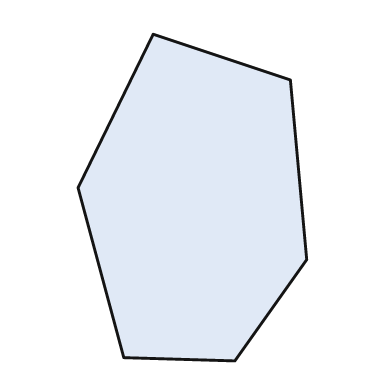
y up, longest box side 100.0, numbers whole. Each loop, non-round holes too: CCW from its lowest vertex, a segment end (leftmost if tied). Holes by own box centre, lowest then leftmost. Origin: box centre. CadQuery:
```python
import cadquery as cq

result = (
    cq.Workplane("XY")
    .moveTo(13.0, -50.0)
    .lineTo(35.0, -19.0)
    .lineTo(30.0, 36.0)
    .lineTo(-12.0, 50.0)
    .lineTo(-35.0, 3.0)
    .lineTo(-21.0, -49.0)
    .close()
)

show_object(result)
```